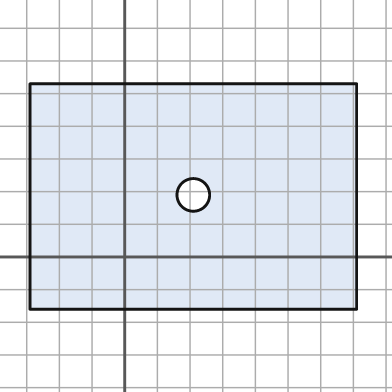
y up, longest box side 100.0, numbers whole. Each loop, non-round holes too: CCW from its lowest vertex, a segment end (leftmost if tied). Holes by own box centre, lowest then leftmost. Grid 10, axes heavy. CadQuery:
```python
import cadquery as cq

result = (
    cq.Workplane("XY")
    .moveTo(-29.0, -16.0)
    .lineTo(71.0, -16.0)
    .lineTo(71.0, 53.0)
    .lineTo(-29.0, 53.0)
    .close()
    .moveTo(21.0, 19.0)
    .circle(5.0)
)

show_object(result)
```